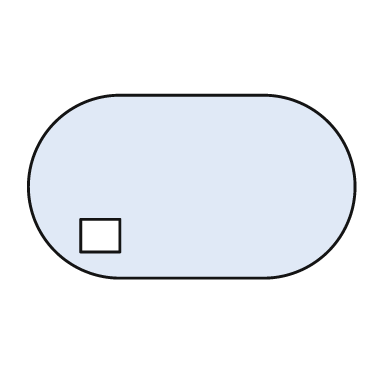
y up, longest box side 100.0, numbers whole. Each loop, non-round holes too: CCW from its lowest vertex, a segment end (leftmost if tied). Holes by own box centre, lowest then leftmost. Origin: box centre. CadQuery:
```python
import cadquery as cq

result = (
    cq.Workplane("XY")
    .moveTo(-22.0, -28.0)
    .lineTo(22.0, -28.0)
    .threePointArc((50.0, 0.0), (22.0, 28.0))
    .lineTo(-22.0, 28.0)
    .threePointArc((-50.0, 0.0), (-22.0, -28.0))
    .close()
    .moveTo(-34.0, -20.0)
    .lineTo(-22.0, -20.0)
    .lineTo(-22.0, -10.0)
    .lineTo(-34.0, -10.0)
    .close()
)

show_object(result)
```